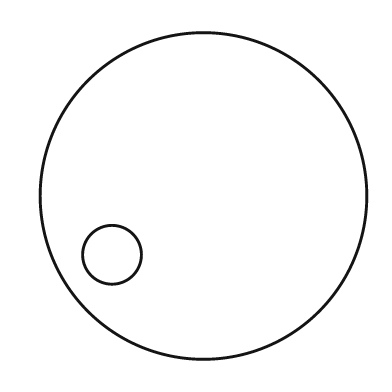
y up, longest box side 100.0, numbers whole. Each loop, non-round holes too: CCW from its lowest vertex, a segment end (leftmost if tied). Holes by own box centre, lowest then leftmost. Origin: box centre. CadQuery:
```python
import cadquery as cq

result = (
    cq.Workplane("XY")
    .moveTo(0.0, 0.0)
    .circle(50.0)
    .moveTo(-28.0, -18.0)
    .circle(9.0)
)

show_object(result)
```